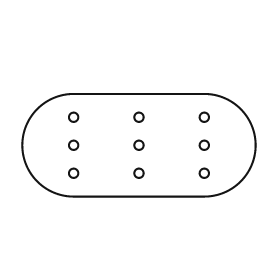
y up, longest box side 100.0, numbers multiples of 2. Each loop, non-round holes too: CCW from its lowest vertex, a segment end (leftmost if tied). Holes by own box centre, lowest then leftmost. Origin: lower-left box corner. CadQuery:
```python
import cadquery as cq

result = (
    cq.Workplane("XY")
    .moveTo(22.0, 0.0)
    .lineTo(78.0, 0.0)
    .threePointArc((100.0, 22.0), (78.0, 44.0))
    .lineTo(22.0, 44.0)
    .threePointArc((0.0, 22.0), (22.0, 0.0))
    .close()
    .moveTo(22.0, 10.0)
    .circle(2.0)
    .moveTo(50.0, 10.0)
    .circle(2.0)
    .moveTo(78.0, 10.0)
    .circle(2.0)
    .moveTo(22.0, 22.0)
    .circle(2.0)
    .moveTo(50.0, 22.0)
    .circle(2.0)
    .moveTo(78.0, 22.0)
    .circle(2.0)
    .moveTo(22.0, 34.0)
    .circle(2.0)
    .moveTo(50.0, 34.0)
    .circle(2.0)
    .moveTo(78.0, 34.0)
    .circle(2.0)
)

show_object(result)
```